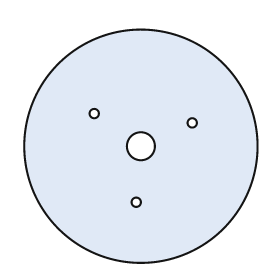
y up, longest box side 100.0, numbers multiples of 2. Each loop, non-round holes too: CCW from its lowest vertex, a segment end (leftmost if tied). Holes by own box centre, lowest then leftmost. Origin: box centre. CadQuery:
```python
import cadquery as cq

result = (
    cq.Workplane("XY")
    .moveTo(0.0, 0.0)
    .circle(50.0)
    .moveTo(-2.0, -24.0)
    .circle(2.0)
    .moveTo(0.0, 0.0)
    .circle(6.0)
    .moveTo(22.0, 10.0)
    .circle(2.0)
    .moveTo(-20.0, 14.0)
    .circle(2.0)
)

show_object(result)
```